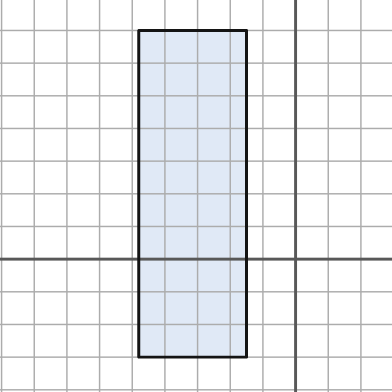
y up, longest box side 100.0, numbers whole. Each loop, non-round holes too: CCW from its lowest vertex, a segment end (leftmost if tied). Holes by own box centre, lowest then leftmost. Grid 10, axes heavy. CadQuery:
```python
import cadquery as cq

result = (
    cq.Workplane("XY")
    .moveTo(-48.0, -30.0)
    .lineTo(-15.0, -30.0)
    .lineTo(-15.0, 70.0)
    .lineTo(-48.0, 70.0)
    .close()
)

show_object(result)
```